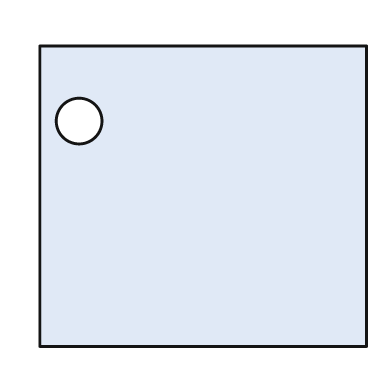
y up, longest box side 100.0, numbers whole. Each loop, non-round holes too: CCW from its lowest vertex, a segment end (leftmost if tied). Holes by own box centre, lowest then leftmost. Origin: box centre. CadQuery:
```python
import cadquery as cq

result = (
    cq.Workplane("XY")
    .moveTo(-50.0, -46.0)
    .lineTo(50.0, -46.0)
    .lineTo(50.0, 46.0)
    .lineTo(-50.0, 46.0)
    .close()
    .moveTo(-38.0, 23.0)
    .circle(7.0)
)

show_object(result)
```